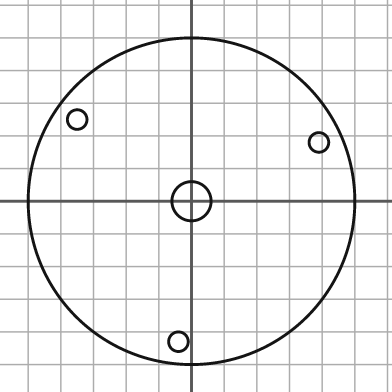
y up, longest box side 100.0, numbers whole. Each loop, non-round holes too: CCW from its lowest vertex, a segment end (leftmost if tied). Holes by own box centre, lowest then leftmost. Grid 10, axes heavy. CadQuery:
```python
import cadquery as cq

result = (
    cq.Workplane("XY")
    .moveTo(0.0, 0.0)
    .circle(50.0)
    .moveTo(-4.0, -43.0)
    .circle(3.0)
    .moveTo(0.0, 0.0)
    .circle(6.0)
    .moveTo(39.0, 18.0)
    .circle(3.0)
    .moveTo(-35.0, 25.0)
    .circle(3.0)
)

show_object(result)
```